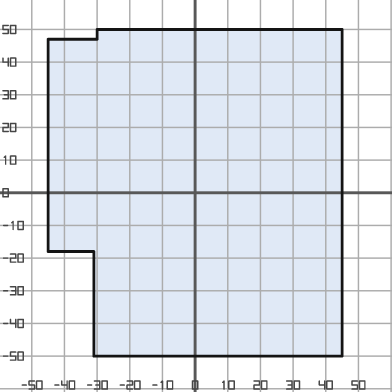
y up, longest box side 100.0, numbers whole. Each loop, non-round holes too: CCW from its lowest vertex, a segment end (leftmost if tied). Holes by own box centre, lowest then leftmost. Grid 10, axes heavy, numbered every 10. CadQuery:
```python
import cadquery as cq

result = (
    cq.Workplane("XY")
    .moveTo(-31.0, -50.0)
    .lineTo(45.0, -50.0)
    .lineTo(45.0, 50.0)
    .lineTo(-30.0, 50.0)
    .lineTo(-30.0, 47.0)
    .lineTo(-45.0, 47.0)
    .lineTo(-45.0, -18.0)
    .lineTo(-31.0, -18.0)
    .close()
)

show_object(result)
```